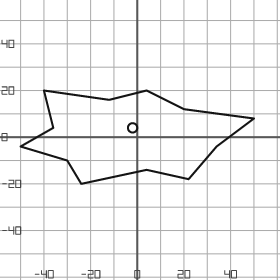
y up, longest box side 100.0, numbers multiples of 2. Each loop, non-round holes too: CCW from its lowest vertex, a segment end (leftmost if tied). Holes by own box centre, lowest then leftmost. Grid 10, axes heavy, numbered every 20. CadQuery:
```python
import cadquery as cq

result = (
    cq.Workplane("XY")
    .moveTo(-24.0, -20.0)
    .lineTo(4.0, -14.0)
    .lineTo(22.0, -18.0)
    .lineTo(34.0, -4.0)
    .lineTo(50.0, 8.0)
    .lineTo(20.0, 12.0)
    .lineTo(4.0, 20.0)
    .lineTo(-12.0, 16.0)
    .lineTo(-40.0, 20.0)
    .lineTo(-36.0, 4.0)
    .lineTo(-50.0, -4.0)
    .lineTo(-30.0, -10.0)
    .close()
    .moveTo(-2.0, 4.0)
    .circle(2.0)
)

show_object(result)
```